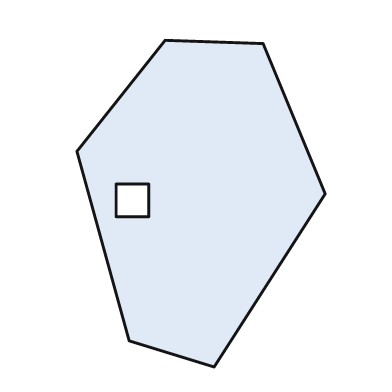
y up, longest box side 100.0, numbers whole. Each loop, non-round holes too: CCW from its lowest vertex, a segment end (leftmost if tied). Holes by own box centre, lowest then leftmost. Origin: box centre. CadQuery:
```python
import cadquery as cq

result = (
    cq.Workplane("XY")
    .moveTo(4.0, -50.0)
    .lineTo(38.0, 3.0)
    .lineTo(19.0, 49.0)
    .lineTo(-11.0, 50.0)
    .lineTo(-38.0, 16.0)
    .lineTo(-22.0, -42.0)
    .close()
    .moveTo(-26.0, -4.0)
    .lineTo(-16.0, -4.0)
    .lineTo(-16.0, 6.0)
    .lineTo(-26.0, 6.0)
    .close()
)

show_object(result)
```